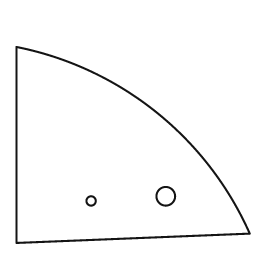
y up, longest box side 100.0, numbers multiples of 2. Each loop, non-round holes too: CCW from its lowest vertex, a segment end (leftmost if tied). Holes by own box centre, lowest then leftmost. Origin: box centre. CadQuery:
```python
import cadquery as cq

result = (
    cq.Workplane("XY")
    .moveTo(-50.0, -42.0)
    .lineTo(50.0, -38.0)
    .threePointArc((10.0, 14.0), (-50.0, 42.0))
    .close()
    .moveTo(-18.0, -24.0)
    .circle(2.0)
    .moveTo(14.0, -22.0)
    .circle(4.0)
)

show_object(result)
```